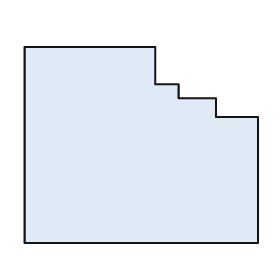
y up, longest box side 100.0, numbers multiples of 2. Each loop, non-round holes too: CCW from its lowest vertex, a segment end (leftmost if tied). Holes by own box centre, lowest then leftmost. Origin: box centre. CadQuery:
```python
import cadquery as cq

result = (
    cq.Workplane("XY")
    .moveTo(-50.0, -42.0)
    .lineTo(50.0, -42.0)
    .lineTo(50.0, 12.0)
    .lineTo(32.0, 12.0)
    .lineTo(32.0, 20.0)
    .lineTo(16.0, 20.0)
    .lineTo(16.0, 26.0)
    .lineTo(6.0, 26.0)
    .lineTo(6.0, 42.0)
    .lineTo(-50.0, 42.0)
    .close()
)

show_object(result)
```